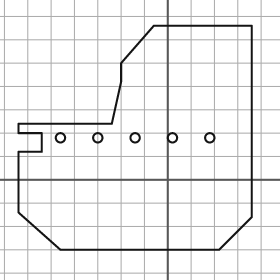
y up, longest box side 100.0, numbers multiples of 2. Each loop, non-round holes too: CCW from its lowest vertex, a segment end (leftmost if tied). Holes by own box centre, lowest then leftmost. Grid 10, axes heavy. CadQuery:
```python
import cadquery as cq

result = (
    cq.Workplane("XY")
    .moveTo(-46.0, -30.0)
    .lineTo(22.0, -30.0)
    .lineTo(36.0, -16.0)
    .lineTo(36.0, 66.0)
    .lineTo(-6.0, 66.0)
    .lineTo(-20.0, 50.0)
    .lineTo(-20.0, 42.0)
    .lineTo(-24.0, 24.0)
    .lineTo(-64.0, 24.0)
    .lineTo(-64.0, 20.0)
    .lineTo(-54.0, 20.0)
    .lineTo(-54.0, 12.0)
    .lineTo(-64.0, 12.0)
    .lineTo(-64.0, -14.0)
    .close()
    .moveTo(-46.0, 18.0)
    .circle(2.0)
    .moveTo(-30.0, 18.0)
    .circle(2.0)
    .moveTo(-14.0, 18.0)
    .circle(2.0)
    .moveTo(2.0, 18.0)
    .circle(2.0)
    .moveTo(18.0, 18.0)
    .circle(2.0)
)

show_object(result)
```